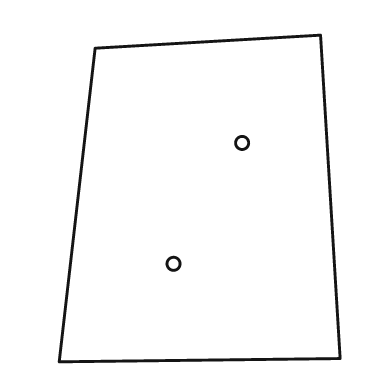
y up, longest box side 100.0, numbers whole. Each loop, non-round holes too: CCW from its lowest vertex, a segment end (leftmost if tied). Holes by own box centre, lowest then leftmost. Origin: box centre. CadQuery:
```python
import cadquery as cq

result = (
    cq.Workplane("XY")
    .moveTo(-43.0, -50.0)
    .lineTo(43.0, -49.0)
    .lineTo(37.0, 50.0)
    .lineTo(-32.0, 46.0)
    .close()
    .moveTo(-8.0, -20.0)
    .circle(2.0)
    .moveTo(13.0, 17.0)
    .circle(2.0)
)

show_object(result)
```